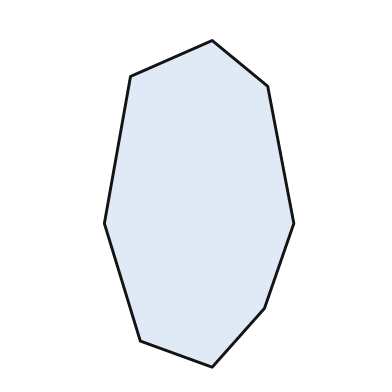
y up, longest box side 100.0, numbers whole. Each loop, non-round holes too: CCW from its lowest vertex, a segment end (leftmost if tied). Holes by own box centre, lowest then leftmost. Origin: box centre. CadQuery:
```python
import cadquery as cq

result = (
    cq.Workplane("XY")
    .moveTo(4.0, -50.0)
    .lineTo(20.0, -32.0)
    .lineTo(29.0, -6.0)
    .lineTo(21.0, 36.0)
    .lineTo(4.0, 50.0)
    .lineTo(-21.0, 39.0)
    .lineTo(-29.0, -6.0)
    .lineTo(-18.0, -42.0)
    .close()
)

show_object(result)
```